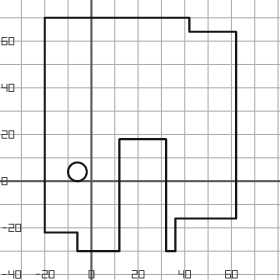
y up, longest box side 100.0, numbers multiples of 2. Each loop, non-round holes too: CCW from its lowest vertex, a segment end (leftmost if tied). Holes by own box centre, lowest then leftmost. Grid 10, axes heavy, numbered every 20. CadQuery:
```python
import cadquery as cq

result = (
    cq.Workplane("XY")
    .moveTo(-6.0, -30.0)
    .lineTo(12.0, -30.0)
    .lineTo(12.0, 18.0)
    .lineTo(32.0, 18.0)
    .lineTo(32.0, -30.0)
    .lineTo(36.0, -30.0)
    .lineTo(36.0, -16.0)
    .lineTo(62.0, -16.0)
    .lineTo(62.0, 64.0)
    .lineTo(42.0, 64.0)
    .lineTo(42.0, 70.0)
    .lineTo(-20.0, 70.0)
    .lineTo(-20.0, -22.0)
    .lineTo(-6.0, -22.0)
    .close()
    .moveTo(-6.0, 4.0)
    .circle(4.0)
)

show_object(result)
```